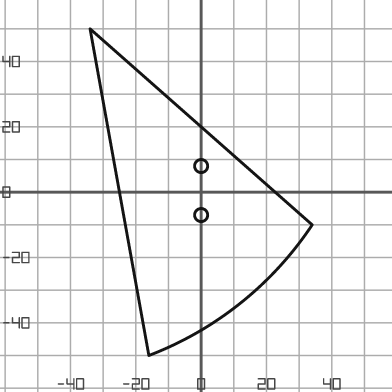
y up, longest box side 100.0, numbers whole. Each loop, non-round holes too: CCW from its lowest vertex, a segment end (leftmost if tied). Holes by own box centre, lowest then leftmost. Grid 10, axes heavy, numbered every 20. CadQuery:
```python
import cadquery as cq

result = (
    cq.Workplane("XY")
    .moveTo(-16.0, -50.0)
    .threePointArc((12.0, -34.0), (34.0, -10.0))
    .lineTo(-34.0, 50.0)
    .close()
    .moveTo(0.0, -7.0)
    .circle(2.0)
    .moveTo(0.0, 8.0)
    .circle(2.0)
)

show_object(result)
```